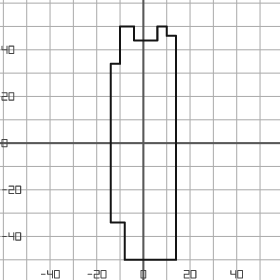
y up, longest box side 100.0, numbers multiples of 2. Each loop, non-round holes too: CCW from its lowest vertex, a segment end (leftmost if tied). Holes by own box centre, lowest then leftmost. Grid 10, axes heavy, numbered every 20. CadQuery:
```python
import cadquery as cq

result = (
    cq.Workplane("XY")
    .moveTo(-8.0, -50.0)
    .lineTo(14.0, -50.0)
    .lineTo(14.0, 46.0)
    .lineTo(10.0, 46.0)
    .lineTo(10.0, 50.0)
    .lineTo(6.0, 50.0)
    .lineTo(6.0, 44.0)
    .lineTo(-4.0, 44.0)
    .lineTo(-4.0, 50.0)
    .lineTo(-10.0, 50.0)
    .lineTo(-10.0, 34.0)
    .lineTo(-14.0, 34.0)
    .lineTo(-14.0, -34.0)
    .lineTo(-8.0, -34.0)
    .close()
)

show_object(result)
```